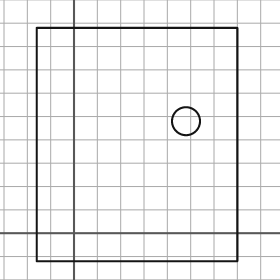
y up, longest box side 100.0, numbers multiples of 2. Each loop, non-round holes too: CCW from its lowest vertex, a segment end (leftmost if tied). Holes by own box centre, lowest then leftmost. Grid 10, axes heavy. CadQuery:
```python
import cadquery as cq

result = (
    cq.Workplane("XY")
    .moveTo(-16.0, -12.0)
    .lineTo(70.0, -12.0)
    .lineTo(70.0, 88.0)
    .lineTo(-16.0, 88.0)
    .close()
    .moveTo(48.0, 48.0)
    .circle(6.0)
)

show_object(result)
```